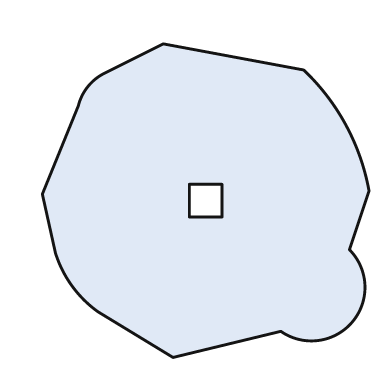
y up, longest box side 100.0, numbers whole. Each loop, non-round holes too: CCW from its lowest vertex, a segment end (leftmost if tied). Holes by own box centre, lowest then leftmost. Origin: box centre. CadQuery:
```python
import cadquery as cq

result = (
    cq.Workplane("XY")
    .moveTo(-10.0, -48.0)
    .lineTo(23.0, -40.0)
    .threePointArc((45.0, -37.0), (44.0, -15.0))
    .lineTo(50.0, 3.0)
    .threePointArc((43.0, 23.0), (30.0, 40.0))
    .lineTo(-13.0, 48.0)
    .lineTo(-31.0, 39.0)
    .threePointArc((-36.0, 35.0), (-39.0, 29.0))
    .lineTo(-50.0, 2.0)
    .lineTo(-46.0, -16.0)
    .threePointArc((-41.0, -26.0), (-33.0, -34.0))
    .close()
    .moveTo(-5.0, -5.0)
    .lineTo(5.0, -5.0)
    .lineTo(5.0, 5.0)
    .lineTo(-5.0, 5.0)
    .close()
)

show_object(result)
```